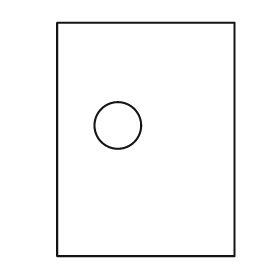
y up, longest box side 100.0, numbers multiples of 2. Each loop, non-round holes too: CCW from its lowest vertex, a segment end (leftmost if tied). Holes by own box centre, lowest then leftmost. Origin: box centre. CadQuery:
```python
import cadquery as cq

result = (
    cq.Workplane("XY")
    .moveTo(-38.0, -50.0)
    .lineTo(38.0, -50.0)
    .lineTo(38.0, 50.0)
    .lineTo(-38.0, 50.0)
    .close()
    .moveTo(-12.0, 6.0)
    .circle(10.0)
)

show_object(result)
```